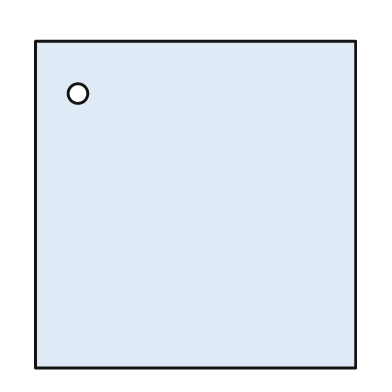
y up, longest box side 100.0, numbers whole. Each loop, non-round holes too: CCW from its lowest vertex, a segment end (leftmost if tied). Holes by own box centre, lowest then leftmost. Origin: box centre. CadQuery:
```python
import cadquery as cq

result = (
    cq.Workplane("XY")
    .moveTo(-49.0, -50.0)
    .lineTo(49.0, -50.0)
    .lineTo(49.0, 50.0)
    .lineTo(-49.0, 50.0)
    .close()
    .moveTo(-36.0, 34.0)
    .circle(3.0)
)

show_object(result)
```